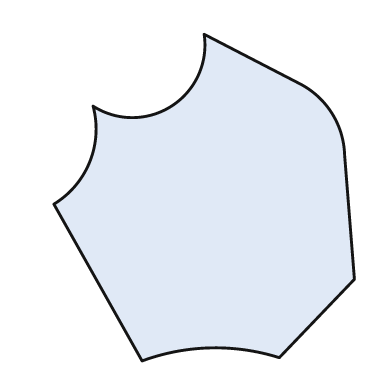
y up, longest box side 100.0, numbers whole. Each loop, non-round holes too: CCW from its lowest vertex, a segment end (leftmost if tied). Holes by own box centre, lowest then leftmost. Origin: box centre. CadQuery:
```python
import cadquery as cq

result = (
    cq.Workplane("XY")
    .moveTo(-19.0, -50.0)
    .threePointArc((2.0, -46.0), (23.0, -49.0))
    .lineTo(46.0, -25.0)
    .lineTo(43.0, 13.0)
    .threePointArc((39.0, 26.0), (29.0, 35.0))
    .lineTo(0.0, 50.0)
    .threePointArc((-10.0, 28.0), (-34.0, 28.0))
    .threePointArc((-35.0, 11.0), (-46.0, -2.0))
    .close()
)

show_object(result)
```